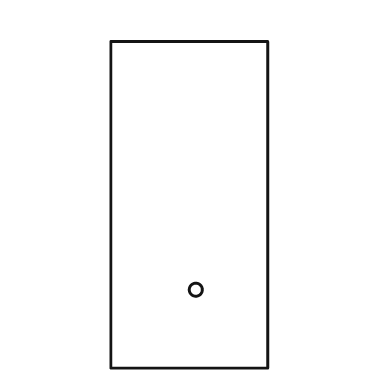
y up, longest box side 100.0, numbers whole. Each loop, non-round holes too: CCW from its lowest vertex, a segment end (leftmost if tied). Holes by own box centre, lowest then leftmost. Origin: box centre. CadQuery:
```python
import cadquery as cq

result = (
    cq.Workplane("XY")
    .moveTo(-24.0, -50.0)
    .lineTo(24.0, -50.0)
    .lineTo(24.0, 50.0)
    .lineTo(-24.0, 50.0)
    .close()
    .moveTo(2.0, -26.0)
    .circle(2.0)
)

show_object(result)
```